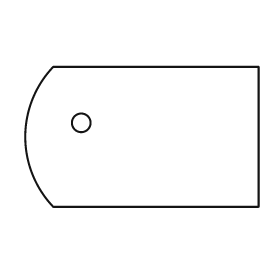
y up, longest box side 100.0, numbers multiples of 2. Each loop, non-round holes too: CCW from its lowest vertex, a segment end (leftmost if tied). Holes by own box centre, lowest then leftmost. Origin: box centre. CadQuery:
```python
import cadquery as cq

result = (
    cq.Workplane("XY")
    .moveTo(-38.0, -30.0)
    .lineTo(50.0, -30.0)
    .lineTo(50.0, 30.0)
    .lineTo(-38.0, 30.0)
    .threePointArc((-50.0, 0.0), (-38.0, -30.0))
    .close()
    .moveTo(-26.0, 6.0)
    .circle(4.0)
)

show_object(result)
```